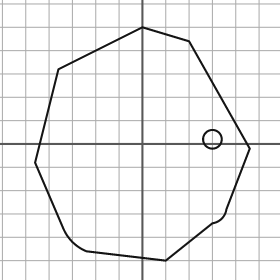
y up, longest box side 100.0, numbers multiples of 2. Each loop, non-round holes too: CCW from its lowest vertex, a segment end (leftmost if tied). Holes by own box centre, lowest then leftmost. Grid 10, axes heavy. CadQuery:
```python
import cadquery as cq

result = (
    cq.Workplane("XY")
    .moveTo(10.0, -50.0)
    .lineTo(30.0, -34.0)
    .threePointArc((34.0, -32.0), (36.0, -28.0))
    .lineTo(46.0, -2.0)
    .lineTo(20.0, 44.0)
    .lineTo(0.0, 50.0)
    .lineTo(-36.0, 32.0)
    .lineTo(-46.0, -8.0)
    .lineTo(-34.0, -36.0)
    .threePointArc((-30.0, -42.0), (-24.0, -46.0))
    .close()
    .moveTo(30.0, 2.0)
    .circle(4.0)
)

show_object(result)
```